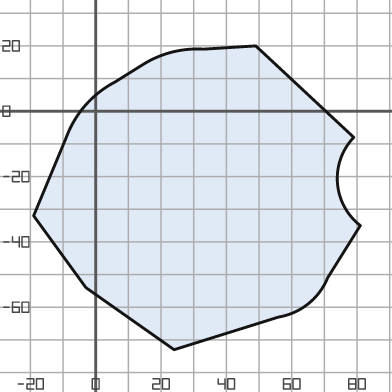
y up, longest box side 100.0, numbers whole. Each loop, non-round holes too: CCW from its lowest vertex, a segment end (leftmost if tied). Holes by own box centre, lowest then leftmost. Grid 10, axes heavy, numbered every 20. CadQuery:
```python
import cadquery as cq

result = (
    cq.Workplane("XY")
    .moveTo(24.0, -73.0)
    .lineTo(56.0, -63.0)
    .threePointArc((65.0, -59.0), (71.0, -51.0))
    .lineTo(81.0, -35.0)
    .threePointArc((74.0, -22.0), (79.0, -8.0))
    .lineTo(49.0, 20.0)
    .lineTo(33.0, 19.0)
    .threePointArc((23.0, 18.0), (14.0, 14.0))
    .lineTo(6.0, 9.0)
    .threePointArc((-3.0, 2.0), (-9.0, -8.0))
    .lineTo(-19.0, -32.0)
    .lineTo(-3.0, -54.0)
    .close()
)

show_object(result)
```